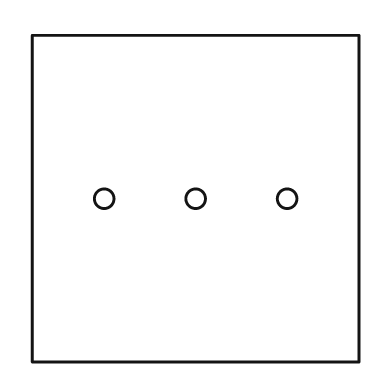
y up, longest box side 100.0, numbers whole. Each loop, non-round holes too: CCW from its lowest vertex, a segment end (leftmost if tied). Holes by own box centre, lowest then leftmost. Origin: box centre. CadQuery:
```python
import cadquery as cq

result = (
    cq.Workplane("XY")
    .moveTo(-50.0, -50.0)
    .lineTo(50.0, -50.0)
    .lineTo(50.0, 50.0)
    .lineTo(-50.0, 50.0)
    .close()
    .moveTo(-28.0, 0.0)
    .circle(3.0)
    .moveTo(0.0, 0.0)
    .circle(3.0)
    .moveTo(28.0, 0.0)
    .circle(3.0)
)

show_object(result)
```